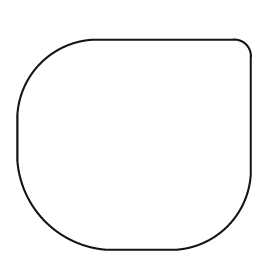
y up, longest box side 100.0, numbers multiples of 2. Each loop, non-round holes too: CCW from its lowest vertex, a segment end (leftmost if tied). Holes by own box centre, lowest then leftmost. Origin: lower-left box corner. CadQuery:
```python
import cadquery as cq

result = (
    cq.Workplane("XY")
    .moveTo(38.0, 0.0)
    .lineTo(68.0, 0.0)
    .threePointArc((90.0, 10.0), (100.0, 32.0))
    .lineTo(100.0, 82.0)
    .threePointArc((98.0, 88.0), (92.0, 90.0))
    .lineTo(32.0, 90.0)
    .threePointArc((10.0, 80.0), (0.0, 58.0))
    .lineTo(0.0, 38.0)
    .threePointArc((12.0, 12.0), (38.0, 0.0))
    .close()
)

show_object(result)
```